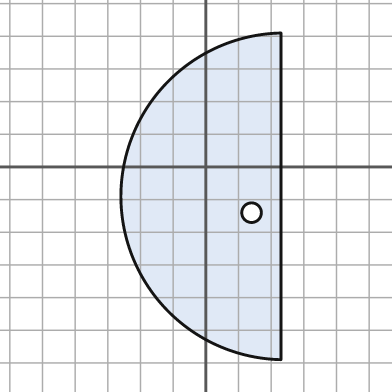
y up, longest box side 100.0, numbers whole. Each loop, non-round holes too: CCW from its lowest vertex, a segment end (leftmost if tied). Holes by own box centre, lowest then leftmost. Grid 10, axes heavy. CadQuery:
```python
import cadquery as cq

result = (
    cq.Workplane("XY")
    .moveTo(23.0, -59.0)
    .lineTo(23.0, 41.0)
    .threePointArc((-26.0, -9.0), (23.0, -59.0))
    .close()
    .moveTo(14.0, -14.0)
    .circle(3.0)
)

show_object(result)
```